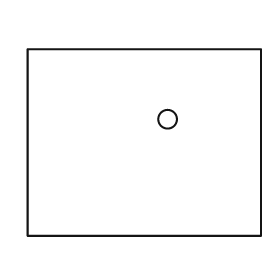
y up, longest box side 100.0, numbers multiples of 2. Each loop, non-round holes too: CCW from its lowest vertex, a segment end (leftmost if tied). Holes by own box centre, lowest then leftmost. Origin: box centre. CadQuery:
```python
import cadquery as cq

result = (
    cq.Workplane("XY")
    .moveTo(-50.0, -40.0)
    .lineTo(50.0, -40.0)
    .lineTo(50.0, 40.0)
    .lineTo(-50.0, 40.0)
    .close()
    .moveTo(10.0, 10.0)
    .circle(4.0)
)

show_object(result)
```